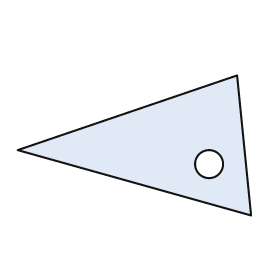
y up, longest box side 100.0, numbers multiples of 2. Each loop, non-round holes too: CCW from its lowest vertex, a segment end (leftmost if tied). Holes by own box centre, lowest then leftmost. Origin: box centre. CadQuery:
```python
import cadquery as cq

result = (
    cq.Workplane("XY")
    .moveTo(50.0, -30.0)
    .lineTo(44.0, 30.0)
    .lineTo(-50.0, -2.0)
    .close()
    .moveTo(32.0, -8.0)
    .circle(6.0)
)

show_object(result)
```